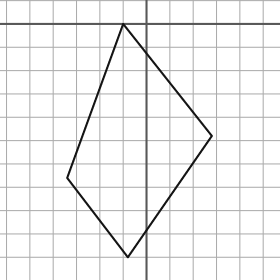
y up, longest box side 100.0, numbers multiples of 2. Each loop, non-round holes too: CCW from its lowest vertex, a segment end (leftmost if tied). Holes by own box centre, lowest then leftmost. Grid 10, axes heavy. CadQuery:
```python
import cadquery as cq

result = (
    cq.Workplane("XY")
    .moveTo(-8.0, -100.0)
    .lineTo(28.0, -48.0)
    .lineTo(-10.0, 0.0)
    .lineTo(-34.0, -66.0)
    .close()
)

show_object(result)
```